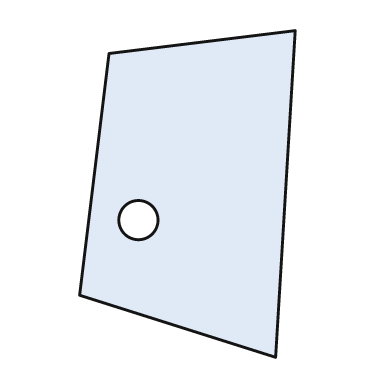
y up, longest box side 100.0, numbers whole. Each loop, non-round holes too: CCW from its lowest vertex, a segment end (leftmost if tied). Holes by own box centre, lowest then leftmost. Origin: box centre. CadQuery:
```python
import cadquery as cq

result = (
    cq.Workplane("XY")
    .moveTo(27.0, -50.0)
    .lineTo(33.0, 50.0)
    .lineTo(-24.0, 43.0)
    .lineTo(-33.0, -31.0)
    .close()
    .moveTo(-15.0, -8.0)
    .circle(6.0)
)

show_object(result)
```